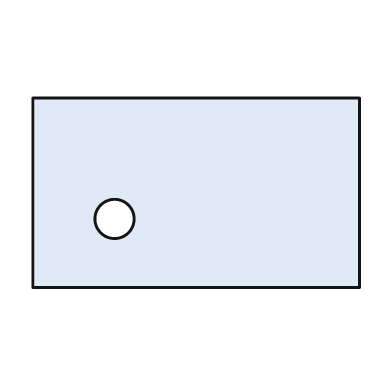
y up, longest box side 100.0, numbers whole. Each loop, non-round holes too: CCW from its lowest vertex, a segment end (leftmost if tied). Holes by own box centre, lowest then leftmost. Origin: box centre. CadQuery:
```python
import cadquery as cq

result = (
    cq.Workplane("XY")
    .moveTo(-50.0, -29.0)
    .lineTo(50.0, -29.0)
    .lineTo(50.0, 29.0)
    .lineTo(-50.0, 29.0)
    .close()
    .moveTo(-25.0, -8.0)
    .circle(6.0)
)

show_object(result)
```